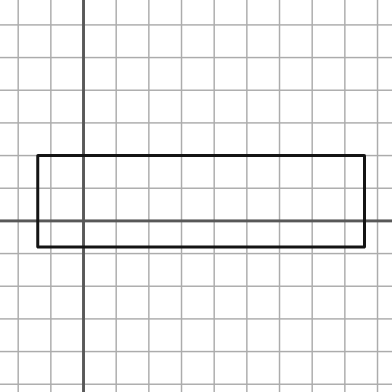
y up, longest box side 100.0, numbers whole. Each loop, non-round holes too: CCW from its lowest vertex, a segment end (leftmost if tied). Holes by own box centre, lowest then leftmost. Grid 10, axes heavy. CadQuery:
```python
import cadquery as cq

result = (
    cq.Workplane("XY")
    .moveTo(-14.0, -8.0)
    .lineTo(86.0, -8.0)
    .lineTo(86.0, 20.0)
    .lineTo(-14.0, 20.0)
    .close()
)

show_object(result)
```